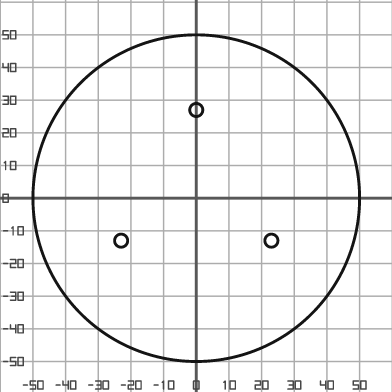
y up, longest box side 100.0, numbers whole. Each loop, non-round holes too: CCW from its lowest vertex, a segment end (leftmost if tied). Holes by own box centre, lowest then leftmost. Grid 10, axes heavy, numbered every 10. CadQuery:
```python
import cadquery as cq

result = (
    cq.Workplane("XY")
    .moveTo(0.0, 0.0)
    .circle(50.0)
    .moveTo(-23.0, -13.0)
    .circle(2.0)
    .moveTo(23.0, -13.0)
    .circle(2.0)
    .moveTo(0.0, 27.0)
    .circle(2.0)
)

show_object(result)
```